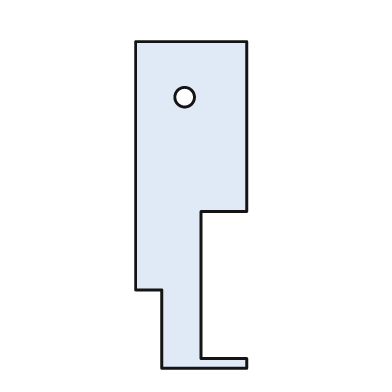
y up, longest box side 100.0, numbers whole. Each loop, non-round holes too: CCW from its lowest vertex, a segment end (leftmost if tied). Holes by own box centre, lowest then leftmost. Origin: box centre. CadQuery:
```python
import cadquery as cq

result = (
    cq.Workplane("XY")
    .moveTo(-9.0, -50.0)
    .lineTo(17.0, -50.0)
    .lineTo(17.0, -47.0)
    .lineTo(3.0, -47.0)
    .lineTo(3.0, -2.0)
    .lineTo(17.0, -2.0)
    .lineTo(17.0, 50.0)
    .lineTo(-17.0, 50.0)
    .lineTo(-17.0, -26.0)
    .lineTo(-9.0, -26.0)
    .close()
    .moveTo(-2.0, 33.0)
    .circle(3.0)
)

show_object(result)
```